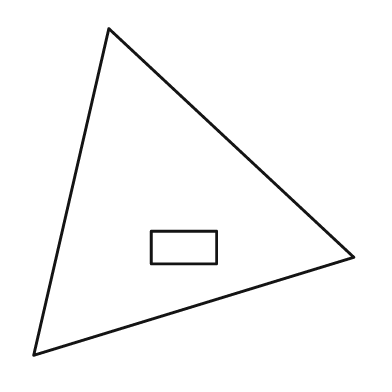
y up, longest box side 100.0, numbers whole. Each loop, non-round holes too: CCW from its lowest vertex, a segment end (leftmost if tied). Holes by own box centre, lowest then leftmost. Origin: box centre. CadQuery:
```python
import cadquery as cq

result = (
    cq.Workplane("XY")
    .moveTo(-49.0, -50.0)
    .lineTo(49.0, -20.0)
    .lineTo(-26.0, 50.0)
    .close()
    .moveTo(-13.0, -22.0)
    .lineTo(7.0, -22.0)
    .lineTo(7.0, -12.0)
    .lineTo(-13.0, -12.0)
    .close()
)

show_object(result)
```